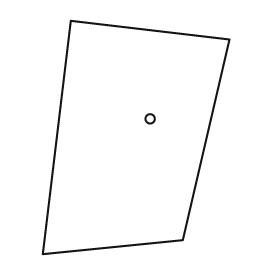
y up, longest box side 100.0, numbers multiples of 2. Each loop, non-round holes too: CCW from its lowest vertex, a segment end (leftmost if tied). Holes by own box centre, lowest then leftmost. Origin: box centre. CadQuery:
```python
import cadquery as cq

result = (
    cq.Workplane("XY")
    .moveTo(-40.0, -50.0)
    .lineTo(20.0, -44.0)
    .lineTo(40.0, 42.0)
    .lineTo(-28.0, 50.0)
    .close()
    .moveTo(6.0, 8.0)
    .circle(2.0)
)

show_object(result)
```